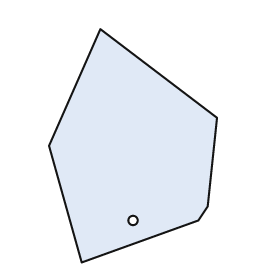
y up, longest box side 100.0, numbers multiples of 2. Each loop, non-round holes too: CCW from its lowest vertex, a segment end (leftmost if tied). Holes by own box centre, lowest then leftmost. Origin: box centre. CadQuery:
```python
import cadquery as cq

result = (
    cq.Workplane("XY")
    .moveTo(-22.0, -50.0)
    .lineTo(28.0, -32.0)
    .lineTo(32.0, -26.0)
    .lineTo(36.0, 12.0)
    .lineTo(-14.0, 50.0)
    .lineTo(-36.0, 0.0)
    .close()
    .moveTo(0.0, -32.0)
    .circle(2.0)
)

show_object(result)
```